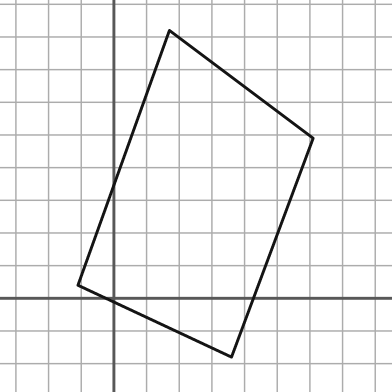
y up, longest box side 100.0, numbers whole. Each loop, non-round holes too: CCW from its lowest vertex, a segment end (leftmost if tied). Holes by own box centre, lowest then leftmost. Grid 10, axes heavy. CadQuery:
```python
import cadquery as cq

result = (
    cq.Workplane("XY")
    .moveTo(36.0, -18.0)
    .lineTo(61.0, 49.0)
    .lineTo(17.0, 82.0)
    .lineTo(-11.0, 4.0)
    .close()
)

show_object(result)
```